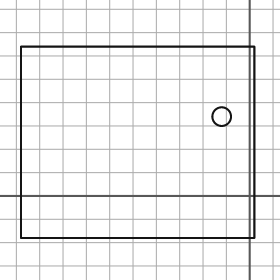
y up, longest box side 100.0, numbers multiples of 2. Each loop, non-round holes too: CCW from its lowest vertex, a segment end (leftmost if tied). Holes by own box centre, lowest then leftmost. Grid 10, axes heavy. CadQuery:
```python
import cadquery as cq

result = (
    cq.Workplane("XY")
    .moveTo(-98.0, -18.0)
    .lineTo(2.0, -18.0)
    .lineTo(2.0, 64.0)
    .lineTo(-98.0, 64.0)
    .close()
    .moveTo(-12.0, 34.0)
    .circle(4.0)
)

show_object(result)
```